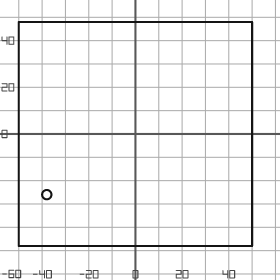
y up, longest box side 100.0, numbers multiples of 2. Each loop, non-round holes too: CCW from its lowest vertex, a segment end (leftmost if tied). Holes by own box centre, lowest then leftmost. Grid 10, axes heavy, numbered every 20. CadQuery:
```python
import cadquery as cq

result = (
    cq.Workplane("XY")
    .moveTo(-50.0, -48.0)
    .lineTo(50.0, -48.0)
    .lineTo(50.0, 48.0)
    .lineTo(-50.0, 48.0)
    .close()
    .moveTo(-38.0, -26.0)
    .circle(2.0)
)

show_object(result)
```